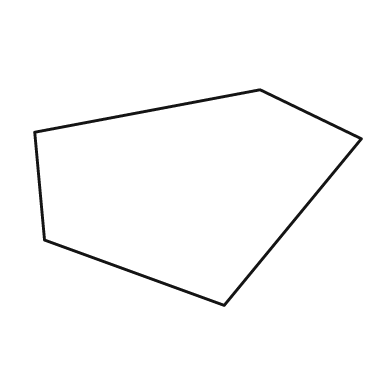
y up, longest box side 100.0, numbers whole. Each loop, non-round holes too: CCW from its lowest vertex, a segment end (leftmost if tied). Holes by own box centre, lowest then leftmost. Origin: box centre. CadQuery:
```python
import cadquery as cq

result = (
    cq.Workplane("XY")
    .moveTo(8.0, -33.0)
    .lineTo(50.0, 18.0)
    .lineTo(19.0, 33.0)
    .lineTo(-50.0, 20.0)
    .lineTo(-47.0, -13.0)
    .close()
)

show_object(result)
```